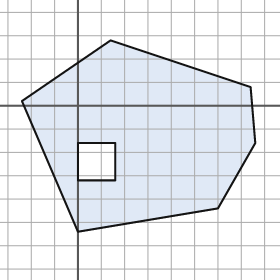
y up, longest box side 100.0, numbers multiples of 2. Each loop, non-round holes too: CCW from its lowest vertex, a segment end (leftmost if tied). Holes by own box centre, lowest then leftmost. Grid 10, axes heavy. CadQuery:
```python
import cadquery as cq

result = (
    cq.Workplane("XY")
    .moveTo(0.0, -54.0)
    .lineTo(60.0, -44.0)
    .lineTo(76.0, -16.0)
    .lineTo(74.0, 8.0)
    .lineTo(14.0, 28.0)
    .lineTo(-24.0, 2.0)
    .close()
    .moveTo(0.0, -32.0)
    .lineTo(16.0, -32.0)
    .lineTo(16.0, -16.0)
    .lineTo(0.0, -16.0)
    .close()
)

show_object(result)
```